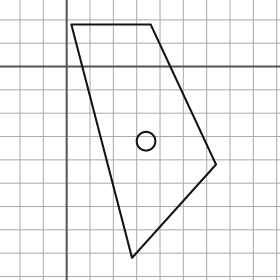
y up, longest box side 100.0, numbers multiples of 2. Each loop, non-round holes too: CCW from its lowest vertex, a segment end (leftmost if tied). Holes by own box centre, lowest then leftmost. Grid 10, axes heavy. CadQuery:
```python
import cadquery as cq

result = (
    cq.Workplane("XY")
    .moveTo(28.0, -82.0)
    .lineTo(64.0, -42.0)
    .lineTo(36.0, 18.0)
    .lineTo(2.0, 18.0)
    .close()
    .moveTo(34.0, -32.0)
    .circle(4.0)
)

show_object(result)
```